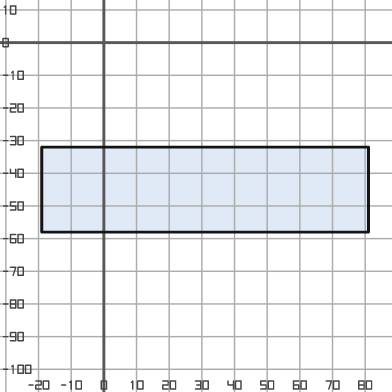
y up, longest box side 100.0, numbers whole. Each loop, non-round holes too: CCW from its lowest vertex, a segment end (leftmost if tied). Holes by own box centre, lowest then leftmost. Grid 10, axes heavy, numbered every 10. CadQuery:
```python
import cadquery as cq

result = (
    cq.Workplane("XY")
    .moveTo(-19.0, -58.0)
    .lineTo(81.0, -58.0)
    .lineTo(81.0, -32.0)
    .lineTo(-19.0, -32.0)
    .close()
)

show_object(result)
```